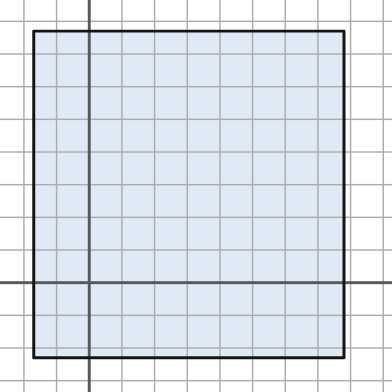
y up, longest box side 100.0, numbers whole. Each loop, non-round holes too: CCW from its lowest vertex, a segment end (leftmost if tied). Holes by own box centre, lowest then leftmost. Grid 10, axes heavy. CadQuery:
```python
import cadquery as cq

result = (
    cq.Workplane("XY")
    .moveTo(-17.0, -23.0)
    .lineTo(78.0, -23.0)
    .lineTo(78.0, 77.0)
    .lineTo(-17.0, 77.0)
    .close()
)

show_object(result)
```